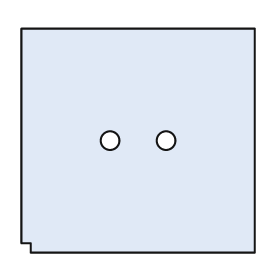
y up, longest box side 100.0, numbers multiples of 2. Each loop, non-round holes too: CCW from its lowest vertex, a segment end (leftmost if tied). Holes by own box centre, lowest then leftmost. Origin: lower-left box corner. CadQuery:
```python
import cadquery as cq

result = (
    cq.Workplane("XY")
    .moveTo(4.0, 0.0)
    .lineTo(100.0, 0.0)
    .lineTo(100.0, 96.0)
    .lineTo(0.0, 96.0)
    .lineTo(0.0, 4.0)
    .lineTo(4.0, 4.0)
    .close()
    .moveTo(38.0, 48.0)
    .circle(4.0)
    .moveTo(62.0, 48.0)
    .circle(4.0)
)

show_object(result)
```